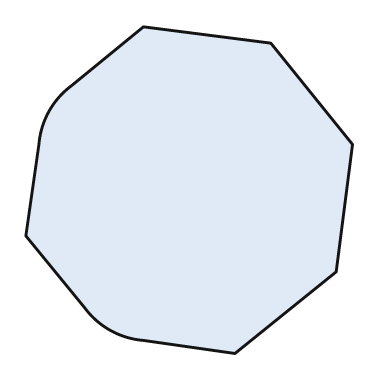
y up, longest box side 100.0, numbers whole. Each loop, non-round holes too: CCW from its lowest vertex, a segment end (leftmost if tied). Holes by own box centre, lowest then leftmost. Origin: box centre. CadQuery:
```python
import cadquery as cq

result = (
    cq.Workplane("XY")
    .moveTo(14.0, -50.0)
    .lineTo(45.0, -25.0)
    .lineTo(50.0, 14.0)
    .lineTo(25.0, 45.0)
    .lineTo(-14.0, 50.0)
    .lineTo(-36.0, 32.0)
    .threePointArc((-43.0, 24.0), (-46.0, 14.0))
    .lineTo(-50.0, -14.0)
    .lineTo(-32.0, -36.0)
    .threePointArc((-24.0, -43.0), (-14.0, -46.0))
    .close()
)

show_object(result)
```